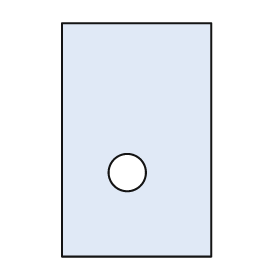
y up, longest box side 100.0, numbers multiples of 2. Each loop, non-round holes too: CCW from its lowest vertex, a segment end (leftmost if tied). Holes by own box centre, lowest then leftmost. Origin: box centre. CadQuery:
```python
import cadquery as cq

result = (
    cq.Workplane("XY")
    .moveTo(-32.0, -50.0)
    .lineTo(32.0, -50.0)
    .lineTo(32.0, 50.0)
    .lineTo(-32.0, 50.0)
    .close()
    .moveTo(-4.0, -14.0)
    .circle(8.0)
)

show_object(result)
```